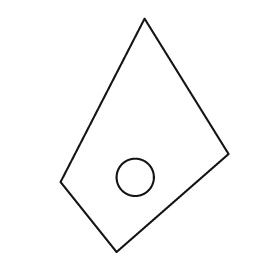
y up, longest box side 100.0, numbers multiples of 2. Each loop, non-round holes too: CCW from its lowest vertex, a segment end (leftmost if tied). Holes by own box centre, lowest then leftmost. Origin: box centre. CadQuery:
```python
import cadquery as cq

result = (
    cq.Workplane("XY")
    .moveTo(-12.0, -50.0)
    .lineTo(36.0, -8.0)
    .lineTo(0.0, 50.0)
    .lineTo(-36.0, -20.0)
    .close()
    .moveTo(-4.0, -18.0)
    .circle(8.0)
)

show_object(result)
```